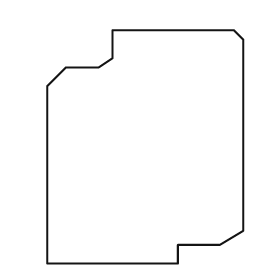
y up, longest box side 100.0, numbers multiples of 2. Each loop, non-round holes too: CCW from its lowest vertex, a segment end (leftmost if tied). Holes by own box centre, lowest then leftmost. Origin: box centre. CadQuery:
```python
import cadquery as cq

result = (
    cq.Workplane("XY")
    .moveTo(-42.0, -50.0)
    .lineTo(14.0, -50.0)
    .lineTo(14.0, -42.0)
    .lineTo(32.0, -42.0)
    .lineTo(42.0, -36.0)
    .lineTo(42.0, 46.0)
    .lineTo(38.0, 50.0)
    .lineTo(-14.0, 50.0)
    .lineTo(-14.0, 38.0)
    .lineTo(-20.0, 34.0)
    .lineTo(-34.0, 34.0)
    .lineTo(-42.0, 26.0)
    .close()
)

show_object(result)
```